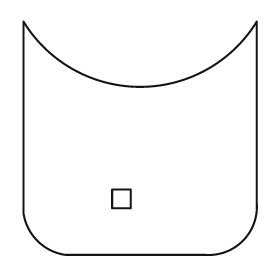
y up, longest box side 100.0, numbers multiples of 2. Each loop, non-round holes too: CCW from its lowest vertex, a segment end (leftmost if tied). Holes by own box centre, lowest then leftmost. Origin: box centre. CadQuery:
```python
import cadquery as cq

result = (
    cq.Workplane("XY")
    .moveTo(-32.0, -50.0)
    .lineTo(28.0, -50.0)
    .threePointArc((44.0, -44.0), (50.0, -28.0))
    .lineTo(50.0, 50.0)
    .threePointArc((0.0, 22.0), (-50.0, 50.0))
    .lineTo(-50.0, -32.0)
    .threePointArc((-44.0, -44.0), (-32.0, -50.0))
    .close()
    .moveTo(-12.0, -30.0)
    .lineTo(-4.0, -30.0)
    .lineTo(-4.0, -22.0)
    .lineTo(-12.0, -22.0)
    .close()
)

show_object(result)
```